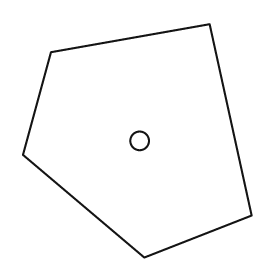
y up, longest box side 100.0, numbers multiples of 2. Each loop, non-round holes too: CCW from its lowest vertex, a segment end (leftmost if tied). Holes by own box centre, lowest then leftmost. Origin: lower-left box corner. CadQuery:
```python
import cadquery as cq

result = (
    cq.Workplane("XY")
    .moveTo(52.0, 0.0)
    .lineTo(98.0, 18.0)
    .lineTo(80.0, 100.0)
    .lineTo(12.0, 88.0)
    .lineTo(0.0, 44.0)
    .close()
    .moveTo(50.0, 50.0)
    .circle(4.0)
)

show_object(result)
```